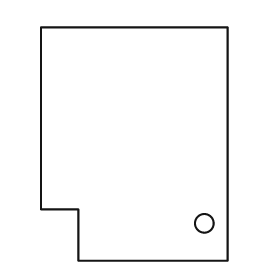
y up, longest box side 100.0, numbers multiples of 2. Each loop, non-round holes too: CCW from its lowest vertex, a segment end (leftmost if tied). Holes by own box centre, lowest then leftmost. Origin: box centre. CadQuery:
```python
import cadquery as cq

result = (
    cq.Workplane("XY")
    .moveTo(-24.0, -50.0)
    .lineTo(40.0, -50.0)
    .lineTo(40.0, 50.0)
    .lineTo(-40.0, 50.0)
    .lineTo(-40.0, -28.0)
    .lineTo(-24.0, -28.0)
    .close()
    .moveTo(30.0, -34.0)
    .circle(4.0)
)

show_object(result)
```